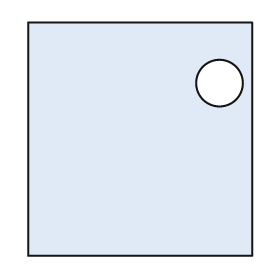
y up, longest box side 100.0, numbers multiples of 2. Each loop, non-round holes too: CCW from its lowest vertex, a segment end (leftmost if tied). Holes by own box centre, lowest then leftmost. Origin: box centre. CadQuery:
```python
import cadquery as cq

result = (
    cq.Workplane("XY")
    .moveTo(-48.0, -50.0)
    .lineTo(48.0, -50.0)
    .lineTo(48.0, 50.0)
    .lineTo(-48.0, 50.0)
    .close()
    .moveTo(34.0, 24.0)
    .circle(10.0)
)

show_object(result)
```